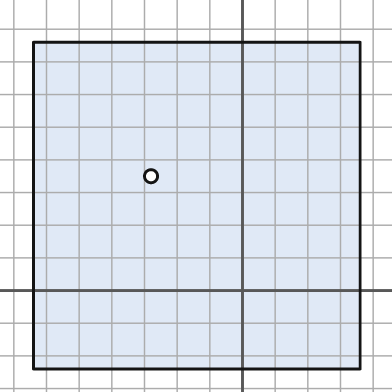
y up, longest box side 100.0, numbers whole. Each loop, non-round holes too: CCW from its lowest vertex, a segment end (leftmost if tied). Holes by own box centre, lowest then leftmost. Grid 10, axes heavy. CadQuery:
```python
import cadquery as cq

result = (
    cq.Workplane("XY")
    .moveTo(-64.0, -24.0)
    .lineTo(36.0, -24.0)
    .lineTo(36.0, 76.0)
    .lineTo(-64.0, 76.0)
    .close()
    .moveTo(-28.0, 35.0)
    .circle(2.0)
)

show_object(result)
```